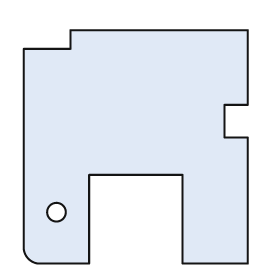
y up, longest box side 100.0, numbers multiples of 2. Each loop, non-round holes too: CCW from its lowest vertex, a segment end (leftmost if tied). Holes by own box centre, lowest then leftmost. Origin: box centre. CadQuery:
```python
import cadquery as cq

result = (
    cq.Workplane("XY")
    .moveTo(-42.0, -50.0)
    .lineTo(-20.0, -50.0)
    .lineTo(-20.0, -12.0)
    .lineTo(20.0, -12.0)
    .lineTo(20.0, -50.0)
    .lineTo(48.0, -50.0)
    .lineTo(48.0, 4.0)
    .lineTo(38.0, 4.0)
    .lineTo(38.0, 18.0)
    .lineTo(48.0, 18.0)
    .lineTo(48.0, 50.0)
    .lineTo(-28.0, 50.0)
    .lineTo(-28.0, 42.0)
    .lineTo(-48.0, 42.0)
    .lineTo(-48.0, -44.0)
    .threePointArc((-46.0, -48.0), (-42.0, -50.0))
    .close()
    .moveTo(-34.0, -28.0)
    .circle(4.0)
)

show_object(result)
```